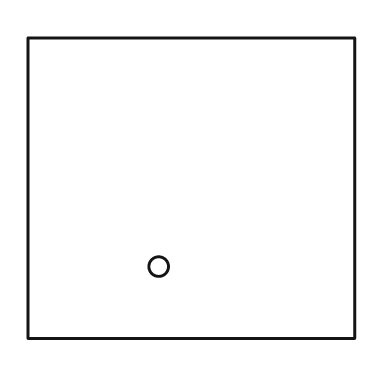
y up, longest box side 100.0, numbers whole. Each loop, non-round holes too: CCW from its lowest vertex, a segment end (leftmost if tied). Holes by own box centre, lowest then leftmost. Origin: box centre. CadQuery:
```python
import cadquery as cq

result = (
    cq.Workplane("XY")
    .moveTo(-50.0, -46.0)
    .lineTo(50.0, -46.0)
    .lineTo(50.0, 46.0)
    .lineTo(-50.0, 46.0)
    .close()
    .moveTo(-10.0, -24.0)
    .circle(3.0)
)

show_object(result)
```